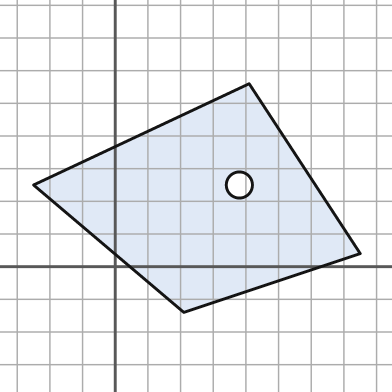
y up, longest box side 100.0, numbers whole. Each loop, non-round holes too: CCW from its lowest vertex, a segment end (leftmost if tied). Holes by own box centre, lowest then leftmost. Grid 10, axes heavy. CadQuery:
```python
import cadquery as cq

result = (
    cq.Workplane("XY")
    .moveTo(21.0, -14.0)
    .lineTo(75.0, 4.0)
    .lineTo(41.0, 56.0)
    .lineTo(-25.0, 25.0)
    .close()
    .moveTo(38.0, 25.0)
    .circle(4.0)
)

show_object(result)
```